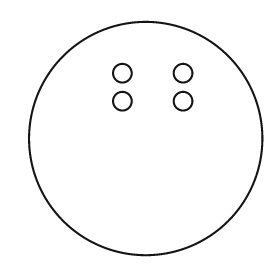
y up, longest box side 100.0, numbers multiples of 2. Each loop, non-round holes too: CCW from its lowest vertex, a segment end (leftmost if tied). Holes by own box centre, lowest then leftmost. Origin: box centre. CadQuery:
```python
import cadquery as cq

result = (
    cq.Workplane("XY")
    .moveTo(0.0, 0.0)
    .circle(50.0)
    .moveTo(-10.0, 16.0)
    .circle(4.0)
    .moveTo(16.0, 16.0)
    .circle(4.0)
    .moveTo(-10.0, 28.0)
    .circle(4.0)
    .moveTo(16.0, 28.0)
    .circle(4.0)
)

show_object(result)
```